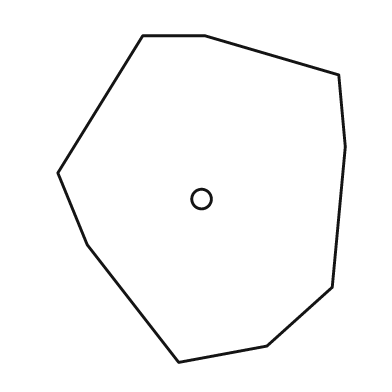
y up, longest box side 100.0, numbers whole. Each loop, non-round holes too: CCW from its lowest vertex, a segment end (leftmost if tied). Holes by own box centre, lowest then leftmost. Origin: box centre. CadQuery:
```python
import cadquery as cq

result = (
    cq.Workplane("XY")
    .moveTo(-7.0, -50.0)
    .lineTo(20.0, -45.0)
    .lineTo(40.0, -27.0)
    .lineTo(44.0, 16.0)
    .lineTo(42.0, 38.0)
    .lineTo(1.0, 50.0)
    .lineTo(-18.0, 50.0)
    .lineTo(-44.0, 8.0)
    .lineTo(-35.0, -14.0)
    .close()
    .moveTo(0.0, 0.0)
    .circle(3.0)
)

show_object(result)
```